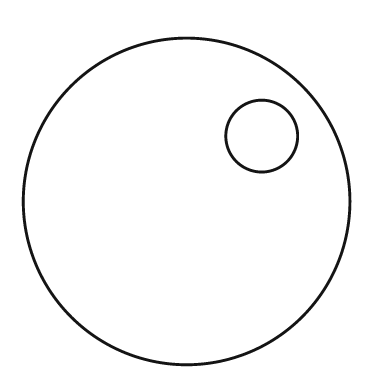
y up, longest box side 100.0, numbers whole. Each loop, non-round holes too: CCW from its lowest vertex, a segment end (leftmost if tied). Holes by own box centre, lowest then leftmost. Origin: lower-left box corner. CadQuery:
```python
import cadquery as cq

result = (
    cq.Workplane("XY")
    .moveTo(50.0, 50.0)
    .circle(50.0)
    .moveTo(73.0, 70.0)
    .circle(11.0)
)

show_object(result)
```